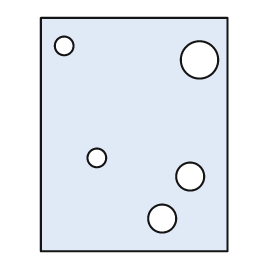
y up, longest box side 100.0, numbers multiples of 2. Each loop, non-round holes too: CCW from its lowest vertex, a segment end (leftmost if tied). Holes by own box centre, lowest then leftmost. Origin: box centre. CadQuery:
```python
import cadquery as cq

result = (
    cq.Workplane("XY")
    .moveTo(-40.0, -50.0)
    .lineTo(40.0, -50.0)
    .lineTo(40.0, 50.0)
    .lineTo(-40.0, 50.0)
    .close()
    .moveTo(12.0, -36.0)
    .circle(6.0)
    .moveTo(24.0, -18.0)
    .circle(6.0)
    .moveTo(-16.0, -10.0)
    .circle(4.0)
    .moveTo(28.0, 32.0)
    .circle(8.0)
    .moveTo(-30.0, 38.0)
    .circle(4.0)
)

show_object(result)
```